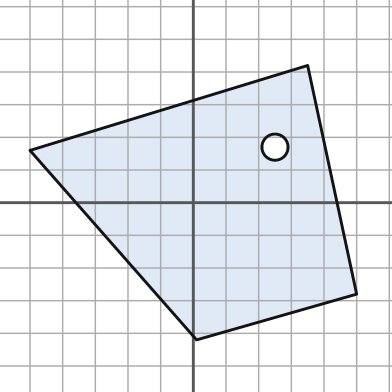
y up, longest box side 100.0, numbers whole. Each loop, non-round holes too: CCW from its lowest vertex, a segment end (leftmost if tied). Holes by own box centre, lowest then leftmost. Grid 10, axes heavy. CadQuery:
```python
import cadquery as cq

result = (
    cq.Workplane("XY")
    .moveTo(1.0, -42.0)
    .lineTo(50.0, -28.0)
    .lineTo(35.0, 42.0)
    .lineTo(-50.0, 16.0)
    .close()
    .moveTo(25.0, 17.0)
    .circle(4.0)
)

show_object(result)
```